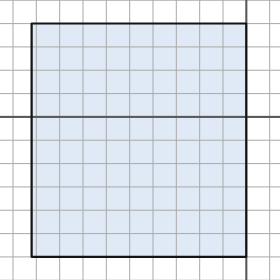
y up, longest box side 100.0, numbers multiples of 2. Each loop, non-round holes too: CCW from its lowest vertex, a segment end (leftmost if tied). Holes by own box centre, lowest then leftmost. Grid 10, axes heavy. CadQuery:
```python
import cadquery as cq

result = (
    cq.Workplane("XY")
    .moveTo(-92.0, -60.0)
    .lineTo(0.0, -60.0)
    .lineTo(0.0, 40.0)
    .lineTo(-92.0, 40.0)
    .close()
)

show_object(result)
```